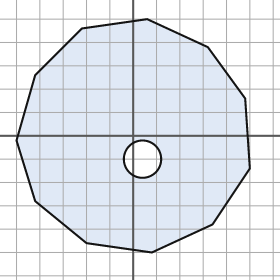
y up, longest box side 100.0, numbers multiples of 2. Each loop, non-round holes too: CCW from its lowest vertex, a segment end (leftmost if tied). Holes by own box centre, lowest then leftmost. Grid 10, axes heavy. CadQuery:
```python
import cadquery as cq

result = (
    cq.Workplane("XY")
    .moveTo(8.0, -50.0)
    .lineTo(34.0, -38.0)
    .lineTo(50.0, -14.0)
    .lineTo(48.0, 16.0)
    .lineTo(32.0, 38.0)
    .lineTo(6.0, 50.0)
    .lineTo(-22.0, 46.0)
    .lineTo(-42.0, 26.0)
    .lineTo(-50.0, -2.0)
    .lineTo(-42.0, -28.0)
    .lineTo(-20.0, -46.0)
    .close()
    .moveTo(4.0, -10.0)
    .circle(8.0)
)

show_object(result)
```